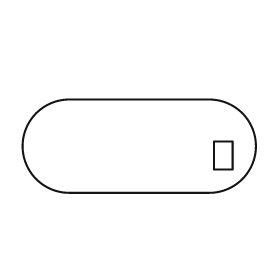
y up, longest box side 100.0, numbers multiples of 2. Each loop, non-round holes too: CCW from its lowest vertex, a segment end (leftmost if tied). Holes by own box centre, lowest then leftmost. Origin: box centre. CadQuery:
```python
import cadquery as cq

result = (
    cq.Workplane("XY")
    .moveTo(-30.0, -20.0)
    .lineTo(30.0, -20.0)
    .threePointArc((50.0, 0.0), (30.0, 20.0))
    .lineTo(-30.0, 20.0)
    .threePointArc((-50.0, 0.0), (-30.0, -20.0))
    .close()
    .moveTo(32.0, -10.0)
    .lineTo(40.0, -10.0)
    .lineTo(40.0, 2.0)
    .lineTo(32.0, 2.0)
    .close()
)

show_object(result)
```